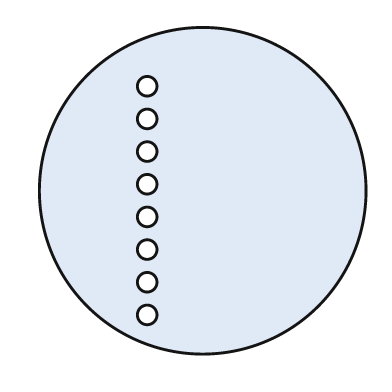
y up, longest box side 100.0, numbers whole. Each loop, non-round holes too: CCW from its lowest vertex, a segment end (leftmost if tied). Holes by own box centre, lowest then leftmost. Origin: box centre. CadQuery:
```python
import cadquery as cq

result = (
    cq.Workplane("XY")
    .moveTo(0.0, 0.0)
    .circle(50.0)
    .moveTo(-17.0, -38.0)
    .circle(3.0)
    .moveTo(-17.0, -28.0)
    .circle(3.0)
    .moveTo(-17.0, -18.0)
    .circle(3.0)
    .moveTo(-17.0, -8.0)
    .circle(3.0)
    .moveTo(-17.0, 2.0)
    .circle(3.0)
    .moveTo(-17.0, 12.0)
    .circle(3.0)
    .moveTo(-17.0, 22.0)
    .circle(3.0)
    .moveTo(-17.0, 32.0)
    .circle(3.0)
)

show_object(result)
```